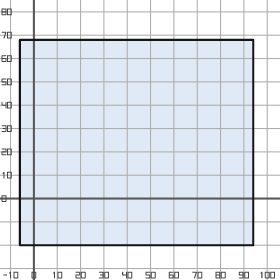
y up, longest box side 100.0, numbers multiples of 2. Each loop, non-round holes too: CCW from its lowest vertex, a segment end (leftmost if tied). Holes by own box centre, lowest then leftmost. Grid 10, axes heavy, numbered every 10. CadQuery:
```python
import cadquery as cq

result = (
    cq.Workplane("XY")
    .moveTo(-6.0, -20.0)
    .lineTo(94.0, -20.0)
    .lineTo(94.0, 68.0)
    .lineTo(-6.0, 68.0)
    .close()
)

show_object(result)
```